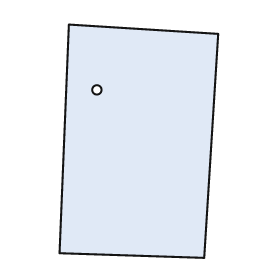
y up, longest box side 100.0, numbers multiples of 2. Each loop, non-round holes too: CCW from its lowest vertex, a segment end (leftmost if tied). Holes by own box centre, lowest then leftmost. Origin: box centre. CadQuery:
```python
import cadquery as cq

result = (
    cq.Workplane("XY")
    .moveTo(28.0, -50.0)
    .lineTo(34.0, 46.0)
    .lineTo(-30.0, 50.0)
    .lineTo(-34.0, -48.0)
    .close()
    .moveTo(-18.0, 22.0)
    .circle(2.0)
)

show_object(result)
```